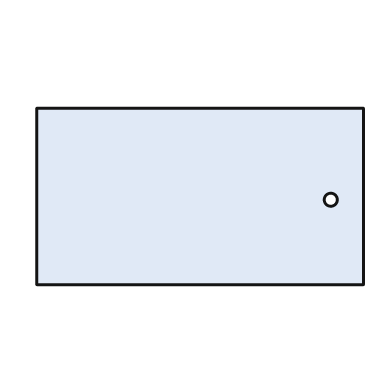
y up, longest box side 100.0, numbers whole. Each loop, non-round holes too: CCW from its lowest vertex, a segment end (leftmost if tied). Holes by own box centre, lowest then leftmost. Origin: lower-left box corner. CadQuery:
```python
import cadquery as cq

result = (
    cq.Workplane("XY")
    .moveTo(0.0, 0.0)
    .lineTo(100.0, 0.0)
    .lineTo(100.0, 54.0)
    .lineTo(0.0, 54.0)
    .close()
    .moveTo(90.0, 26.0)
    .circle(2.0)
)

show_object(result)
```